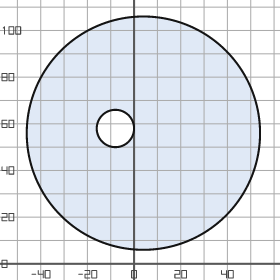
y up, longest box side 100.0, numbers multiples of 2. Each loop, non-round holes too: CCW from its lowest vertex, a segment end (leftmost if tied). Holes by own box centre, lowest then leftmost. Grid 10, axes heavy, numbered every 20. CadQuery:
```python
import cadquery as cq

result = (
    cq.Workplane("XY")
    .moveTo(4.0, 56.0)
    .circle(50.0)
    .moveTo(-8.0, 58.0)
    .circle(8.0)
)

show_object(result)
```